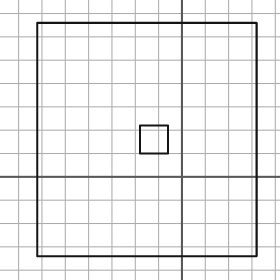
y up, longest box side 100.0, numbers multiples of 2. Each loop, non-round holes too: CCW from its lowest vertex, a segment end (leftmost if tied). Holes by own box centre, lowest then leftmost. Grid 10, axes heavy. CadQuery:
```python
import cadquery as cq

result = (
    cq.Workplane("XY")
    .moveTo(-62.0, -34.0)
    .lineTo(32.0, -34.0)
    .lineTo(32.0, 66.0)
    .lineTo(-62.0, 66.0)
    .close()
    .moveTo(-18.0, 10.0)
    .lineTo(-6.0, 10.0)
    .lineTo(-6.0, 22.0)
    .lineTo(-18.0, 22.0)
    .close()
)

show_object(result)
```